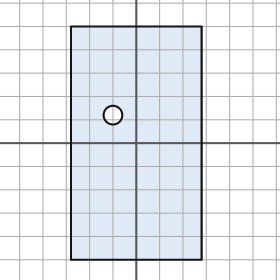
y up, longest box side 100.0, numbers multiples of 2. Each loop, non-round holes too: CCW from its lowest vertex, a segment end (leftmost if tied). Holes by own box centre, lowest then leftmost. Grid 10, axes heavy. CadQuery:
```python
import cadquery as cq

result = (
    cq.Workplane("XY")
    .moveTo(-28.0, -50.0)
    .lineTo(28.0, -50.0)
    .lineTo(28.0, 50.0)
    .lineTo(-28.0, 50.0)
    .close()
    .moveTo(-10.0, 12.0)
    .circle(4.0)
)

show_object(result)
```